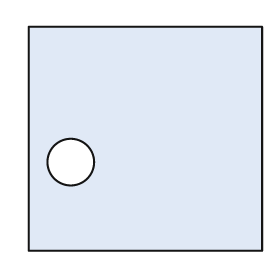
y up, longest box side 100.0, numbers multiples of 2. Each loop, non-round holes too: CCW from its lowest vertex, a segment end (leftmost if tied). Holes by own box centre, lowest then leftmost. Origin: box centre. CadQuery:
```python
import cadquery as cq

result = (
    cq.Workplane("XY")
    .moveTo(-50.0, -48.0)
    .lineTo(50.0, -48.0)
    .lineTo(50.0, 48.0)
    .lineTo(-50.0, 48.0)
    .close()
    .moveTo(-32.0, -10.0)
    .circle(10.0)
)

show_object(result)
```